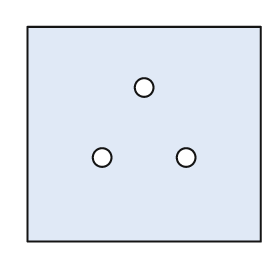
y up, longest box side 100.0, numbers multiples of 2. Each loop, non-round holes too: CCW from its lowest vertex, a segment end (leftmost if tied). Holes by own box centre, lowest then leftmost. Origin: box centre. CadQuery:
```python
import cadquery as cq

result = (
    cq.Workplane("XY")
    .moveTo(-50.0, -46.0)
    .lineTo(50.0, -46.0)
    .lineTo(50.0, 46.0)
    .lineTo(-50.0, 46.0)
    .close()
    .moveTo(-18.0, -10.0)
    .circle(4.0)
    .moveTo(18.0, -10.0)
    .circle(4.0)
    .moveTo(0.0, 20.0)
    .circle(4.0)
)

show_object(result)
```